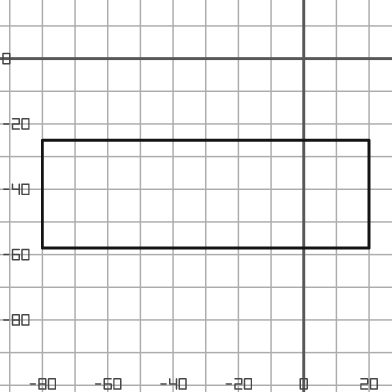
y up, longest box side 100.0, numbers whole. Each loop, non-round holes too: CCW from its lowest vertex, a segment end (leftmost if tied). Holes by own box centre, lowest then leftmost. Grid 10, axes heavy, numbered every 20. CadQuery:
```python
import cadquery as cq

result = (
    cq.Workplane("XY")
    .moveTo(-80.0, -58.0)
    .lineTo(20.0, -58.0)
    .lineTo(20.0, -25.0)
    .lineTo(-80.0, -25.0)
    .close()
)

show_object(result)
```